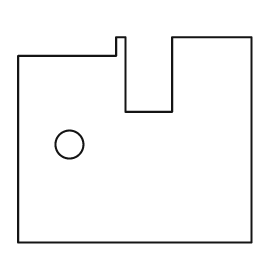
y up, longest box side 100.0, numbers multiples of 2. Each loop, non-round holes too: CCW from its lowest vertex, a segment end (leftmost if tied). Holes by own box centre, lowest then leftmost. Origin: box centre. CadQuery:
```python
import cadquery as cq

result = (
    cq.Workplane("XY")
    .moveTo(-50.0, -44.0)
    .lineTo(50.0, -44.0)
    .lineTo(50.0, 44.0)
    .lineTo(16.0, 44.0)
    .lineTo(16.0, 12.0)
    .lineTo(-4.0, 12.0)
    .lineTo(-4.0, 44.0)
    .lineTo(-8.0, 44.0)
    .lineTo(-8.0, 36.0)
    .lineTo(-50.0, 36.0)
    .close()
    .moveTo(-28.0, -2.0)
    .circle(6.0)
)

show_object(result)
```